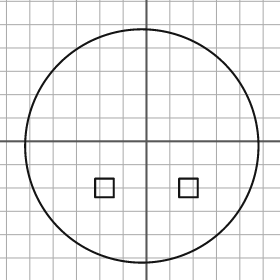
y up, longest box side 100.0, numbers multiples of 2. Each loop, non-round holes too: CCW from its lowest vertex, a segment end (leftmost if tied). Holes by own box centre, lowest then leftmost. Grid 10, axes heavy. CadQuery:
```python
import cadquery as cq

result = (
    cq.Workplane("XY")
    .moveTo(-2.0, -2.0)
    .circle(50.0)
    .moveTo(-22.0, -24.0)
    .lineTo(-14.0, -24.0)
    .lineTo(-14.0, -16.0)
    .lineTo(-22.0, -16.0)
    .close()
    .moveTo(14.0, -24.0)
    .lineTo(22.0, -24.0)
    .lineTo(22.0, -16.0)
    .lineTo(14.0, -16.0)
    .close()
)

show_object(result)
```